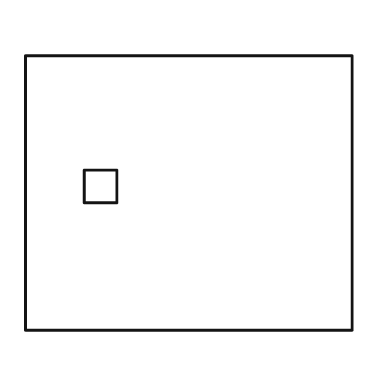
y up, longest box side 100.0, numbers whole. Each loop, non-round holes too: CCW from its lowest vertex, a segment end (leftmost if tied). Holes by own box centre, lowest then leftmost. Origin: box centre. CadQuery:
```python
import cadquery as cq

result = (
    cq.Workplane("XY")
    .moveTo(-50.0, -42.0)
    .lineTo(50.0, -42.0)
    .lineTo(50.0, 42.0)
    .lineTo(-50.0, 42.0)
    .close()
    .moveTo(-32.0, -3.0)
    .lineTo(-22.0, -3.0)
    .lineTo(-22.0, 7.0)
    .lineTo(-32.0, 7.0)
    .close()
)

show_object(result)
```